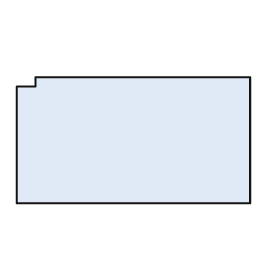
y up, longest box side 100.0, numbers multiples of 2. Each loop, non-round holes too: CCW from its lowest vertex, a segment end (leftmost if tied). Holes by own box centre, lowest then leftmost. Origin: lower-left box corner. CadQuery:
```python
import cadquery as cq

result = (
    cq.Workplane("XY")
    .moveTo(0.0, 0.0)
    .lineTo(100.0, 0.0)
    .lineTo(100.0, 54.0)
    .lineTo(8.0, 54.0)
    .lineTo(8.0, 50.0)
    .lineTo(0.0, 50.0)
    .close()
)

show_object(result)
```